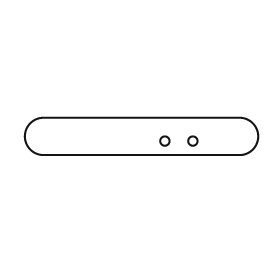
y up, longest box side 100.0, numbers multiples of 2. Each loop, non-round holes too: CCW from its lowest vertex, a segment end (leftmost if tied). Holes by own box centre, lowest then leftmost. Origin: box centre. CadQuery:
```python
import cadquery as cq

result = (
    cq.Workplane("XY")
    .moveTo(-42.0, -8.0)
    .lineTo(42.0, -8.0)
    .threePointArc((50.0, 0.0), (42.0, 8.0))
    .lineTo(-42.0, 8.0)
    .threePointArc((-50.0, 0.0), (-42.0, -8.0))
    .close()
    .moveTo(10.0, -2.0)
    .circle(2.0)
    .moveTo(22.0, -2.0)
    .circle(2.0)
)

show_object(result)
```